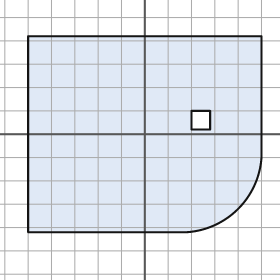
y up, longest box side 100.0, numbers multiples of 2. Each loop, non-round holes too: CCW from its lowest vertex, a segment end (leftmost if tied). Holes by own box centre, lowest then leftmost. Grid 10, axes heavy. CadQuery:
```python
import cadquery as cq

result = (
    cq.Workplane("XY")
    .moveTo(-50.0, -42.0)
    .lineTo(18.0, -42.0)
    .threePointArc((40.0, -32.0), (50.0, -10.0))
    .lineTo(50.0, 42.0)
    .lineTo(-50.0, 42.0)
    .close()
    .moveTo(20.0, 2.0)
    .lineTo(28.0, 2.0)
    .lineTo(28.0, 10.0)
    .lineTo(20.0, 10.0)
    .close()
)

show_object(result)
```